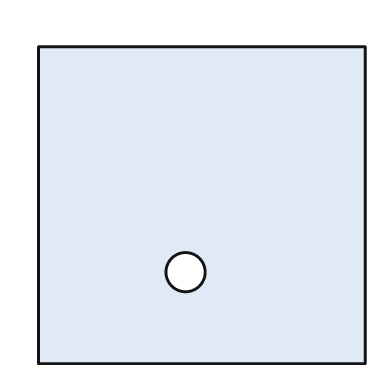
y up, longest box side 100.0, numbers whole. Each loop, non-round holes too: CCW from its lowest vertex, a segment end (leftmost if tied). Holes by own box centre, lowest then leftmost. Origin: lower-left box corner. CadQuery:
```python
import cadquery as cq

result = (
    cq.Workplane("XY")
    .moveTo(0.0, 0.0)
    .lineTo(100.0, 0.0)
    .lineTo(100.0, 97.0)
    .lineTo(0.0, 97.0)
    .close()
    .moveTo(45.0, 28.0)
    .circle(6.0)
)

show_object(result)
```